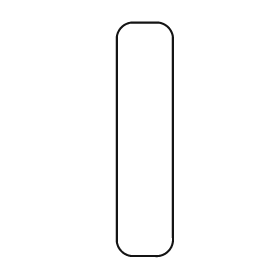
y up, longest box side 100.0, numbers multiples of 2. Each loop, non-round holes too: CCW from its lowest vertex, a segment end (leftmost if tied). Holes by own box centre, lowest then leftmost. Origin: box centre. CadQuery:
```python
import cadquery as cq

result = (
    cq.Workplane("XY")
    .moveTo(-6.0, -50.0)
    .lineTo(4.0, -50.0)
    .threePointArc((10.0, -48.0), (12.0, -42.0))
    .lineTo(12.0, 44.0)
    .threePointArc((10.0, 48.0), (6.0, 50.0))
    .lineTo(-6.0, 50.0)
    .threePointArc((-10.0, 48.0), (-12.0, 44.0))
    .lineTo(-12.0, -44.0)
    .threePointArc((-10.0, -48.0), (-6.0, -50.0))
    .close()
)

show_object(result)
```